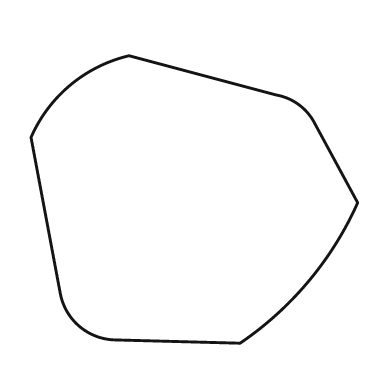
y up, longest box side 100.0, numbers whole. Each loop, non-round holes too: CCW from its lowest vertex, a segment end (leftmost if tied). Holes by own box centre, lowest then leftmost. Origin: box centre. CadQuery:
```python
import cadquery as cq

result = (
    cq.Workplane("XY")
    .moveTo(14.0, -44.0)
    .threePointArc((35.0, -25.0), (50.0, -1.0))
    .lineTo(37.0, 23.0)
    .threePointArc((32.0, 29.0), (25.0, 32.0))
    .lineTo(-20.0, 44.0)
    .threePointArc((-38.0, 35.0), (-50.0, 19.0))
    .lineTo(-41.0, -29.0)
    .threePointArc((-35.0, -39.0), (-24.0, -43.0))
    .close()
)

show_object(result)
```